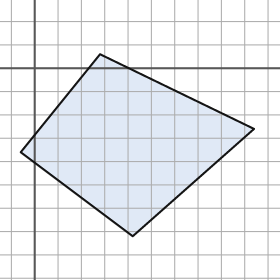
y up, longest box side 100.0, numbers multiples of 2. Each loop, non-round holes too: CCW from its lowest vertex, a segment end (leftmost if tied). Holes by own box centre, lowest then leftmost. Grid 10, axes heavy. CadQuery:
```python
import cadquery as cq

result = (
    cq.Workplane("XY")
    .moveTo(42.0, -72.0)
    .lineTo(94.0, -26.0)
    .lineTo(28.0, 6.0)
    .lineTo(-6.0, -36.0)
    .close()
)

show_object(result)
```